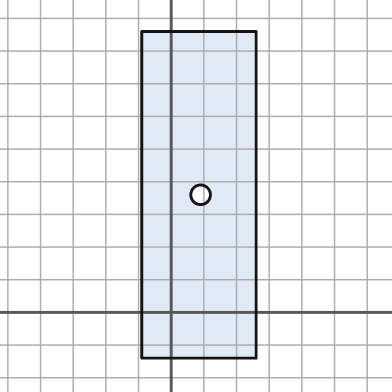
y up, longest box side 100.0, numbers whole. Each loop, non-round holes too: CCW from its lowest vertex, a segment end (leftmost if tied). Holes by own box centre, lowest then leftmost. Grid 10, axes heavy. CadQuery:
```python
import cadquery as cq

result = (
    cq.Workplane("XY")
    .moveTo(-9.0, -14.0)
    .lineTo(26.0, -14.0)
    .lineTo(26.0, 86.0)
    .lineTo(-9.0, 86.0)
    .close()
    .moveTo(9.0, 36.0)
    .circle(3.0)
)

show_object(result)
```